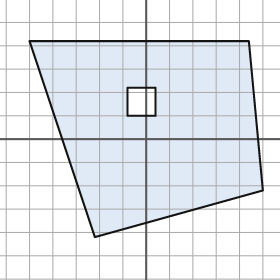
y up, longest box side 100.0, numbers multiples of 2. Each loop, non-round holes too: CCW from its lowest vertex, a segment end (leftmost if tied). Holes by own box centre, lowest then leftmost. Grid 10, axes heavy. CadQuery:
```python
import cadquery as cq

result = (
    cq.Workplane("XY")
    .moveTo(-22.0, -42.0)
    .lineTo(50.0, -22.0)
    .lineTo(44.0, 42.0)
    .lineTo(-50.0, 42.0)
    .close()
    .moveTo(-8.0, 10.0)
    .lineTo(4.0, 10.0)
    .lineTo(4.0, 22.0)
    .lineTo(-8.0, 22.0)
    .close()
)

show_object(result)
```